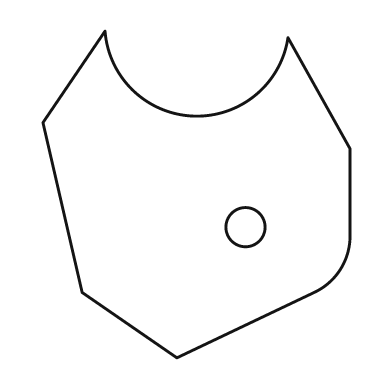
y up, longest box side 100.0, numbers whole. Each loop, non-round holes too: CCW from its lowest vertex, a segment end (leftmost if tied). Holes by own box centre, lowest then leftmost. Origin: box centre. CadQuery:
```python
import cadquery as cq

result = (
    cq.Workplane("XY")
    .moveTo(-6.0, -50.0)
    .lineTo(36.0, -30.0)
    .threePointArc((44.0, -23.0), (47.0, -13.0))
    .lineTo(47.0, 14.0)
    .lineTo(28.0, 48.0)
    .threePointArc((-1.0, 24.0), (-28.0, 50.0))
    .lineTo(-47.0, 22.0)
    .lineTo(-35.0, -30.0)
    .close()
    .moveTo(15.0, -10.0)
    .circle(6.0)
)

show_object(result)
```